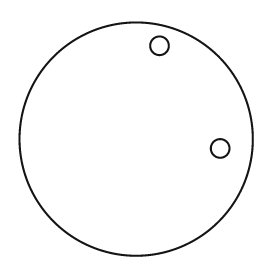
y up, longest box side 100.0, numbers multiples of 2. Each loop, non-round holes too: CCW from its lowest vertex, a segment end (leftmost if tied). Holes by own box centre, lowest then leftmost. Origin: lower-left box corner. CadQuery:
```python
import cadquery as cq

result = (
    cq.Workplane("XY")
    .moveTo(50.0, 50.0)
    .circle(50.0)
    .moveTo(86.0, 46.0)
    .circle(4.0)
    .moveTo(60.0, 90.0)
    .circle(4.0)
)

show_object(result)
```